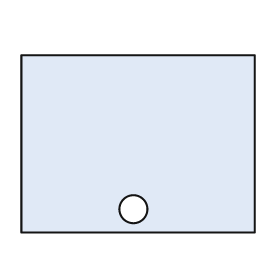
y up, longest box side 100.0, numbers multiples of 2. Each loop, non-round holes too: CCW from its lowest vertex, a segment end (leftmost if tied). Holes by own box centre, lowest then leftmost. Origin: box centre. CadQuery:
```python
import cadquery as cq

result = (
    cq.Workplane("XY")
    .moveTo(-50.0, -38.0)
    .lineTo(50.0, -38.0)
    .lineTo(50.0, 38.0)
    .lineTo(-50.0, 38.0)
    .close()
    .moveTo(-2.0, -28.0)
    .circle(6.0)
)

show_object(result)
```